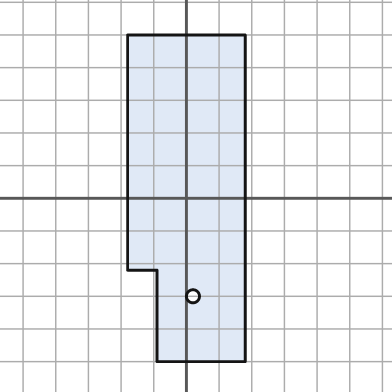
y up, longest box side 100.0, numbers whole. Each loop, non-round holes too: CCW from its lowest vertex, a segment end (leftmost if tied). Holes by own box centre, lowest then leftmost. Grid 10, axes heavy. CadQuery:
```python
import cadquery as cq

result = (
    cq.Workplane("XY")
    .moveTo(-9.0, -50.0)
    .lineTo(18.0, -50.0)
    .lineTo(18.0, 50.0)
    .lineTo(-18.0, 50.0)
    .lineTo(-18.0, -22.0)
    .lineTo(-9.0, -22.0)
    .close()
    .moveTo(2.0, -30.0)
    .circle(2.0)
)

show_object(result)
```